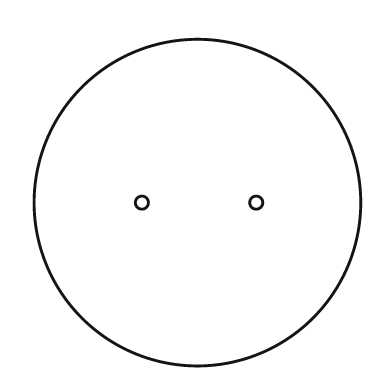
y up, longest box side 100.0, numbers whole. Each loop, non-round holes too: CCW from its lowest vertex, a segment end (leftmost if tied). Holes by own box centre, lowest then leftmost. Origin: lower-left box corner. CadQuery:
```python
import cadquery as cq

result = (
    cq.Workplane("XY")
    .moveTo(50.0, 50.0)
    .circle(50.0)
    .moveTo(33.0, 50.0)
    .circle(2.0)
    .moveTo(68.0, 50.0)
    .circle(2.0)
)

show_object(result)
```